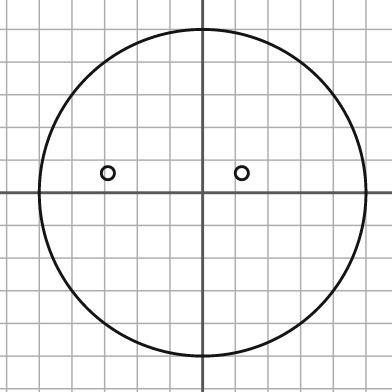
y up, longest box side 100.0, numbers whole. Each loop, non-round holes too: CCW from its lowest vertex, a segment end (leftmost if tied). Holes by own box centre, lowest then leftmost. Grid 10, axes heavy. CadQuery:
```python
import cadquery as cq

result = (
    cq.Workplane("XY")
    .moveTo(0.0, 0.0)
    .circle(50.0)
    .moveTo(-29.0, 6.0)
    .circle(2.0)
    .moveTo(12.0, 6.0)
    .circle(2.0)
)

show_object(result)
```